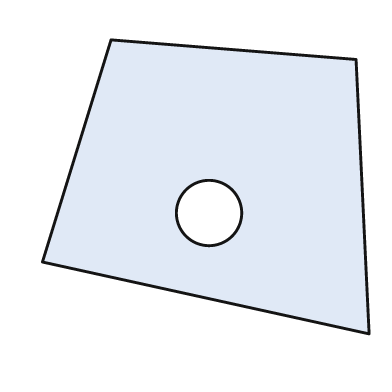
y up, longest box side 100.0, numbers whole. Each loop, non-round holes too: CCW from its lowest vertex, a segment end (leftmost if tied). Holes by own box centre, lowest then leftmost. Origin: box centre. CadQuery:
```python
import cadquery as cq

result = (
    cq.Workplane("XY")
    .moveTo(50.0, -45.0)
    .lineTo(46.0, 39.0)
    .lineTo(-29.0, 45.0)
    .lineTo(-50.0, -23.0)
    .close()
    .moveTo(1.0, -8.0)
    .circle(10.0)
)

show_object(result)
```